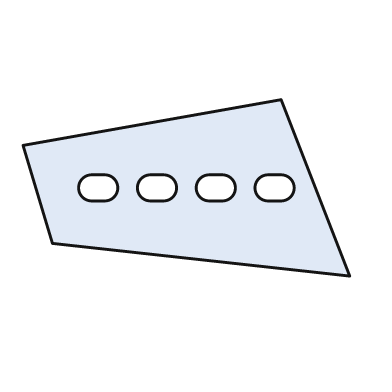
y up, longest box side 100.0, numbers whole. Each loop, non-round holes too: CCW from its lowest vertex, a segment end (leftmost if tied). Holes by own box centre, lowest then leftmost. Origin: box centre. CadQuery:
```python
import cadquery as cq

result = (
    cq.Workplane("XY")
    .moveTo(50.0, -27.0)
    .lineTo(29.0, 27.0)
    .lineTo(-50.0, 13.0)
    .lineTo(-41.0, -17.0)
    .close()
    .moveTo(-29.0, -4.0)
    .lineTo(-25.0, -4.0)
    .threePointArc((-21.0, 0.0), (-25.0, 4.0))
    .lineTo(-29.0, 4.0)
    .threePointArc((-33.0, 0.0), (-29.0, -4.0))
    .close()
    .moveTo(-11.0, -4.0)
    .lineTo(-7.0, -4.0)
    .threePointArc((-3.0, 0.0), (-7.0, 4.0))
    .lineTo(-11.0, 4.0)
    .threePointArc((-15.0, 0.0), (-11.0, -4.0))
    .close()
    .moveTo(7.0, -4.0)
    .lineTo(11.0, -4.0)
    .threePointArc((15.0, 0.0), (11.0, 4.0))
    .lineTo(7.0, 4.0)
    .threePointArc((3.0, 0.0), (7.0, -4.0))
    .close()
    .moveTo(25.0, -4.0)
    .lineTo(29.0, -4.0)
    .threePointArc((33.0, 0.0), (29.0, 4.0))
    .lineTo(25.0, 4.0)
    .threePointArc((21.0, 0.0), (25.0, -4.0))
    .close()
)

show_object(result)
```